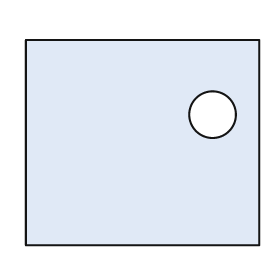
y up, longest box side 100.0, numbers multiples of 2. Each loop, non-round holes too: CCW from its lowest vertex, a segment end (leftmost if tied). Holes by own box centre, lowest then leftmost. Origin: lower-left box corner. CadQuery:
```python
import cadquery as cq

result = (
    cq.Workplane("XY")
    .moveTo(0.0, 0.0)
    .lineTo(100.0, 0.0)
    .lineTo(100.0, 88.0)
    .lineTo(0.0, 88.0)
    .close()
    .moveTo(80.0, 56.0)
    .circle(10.0)
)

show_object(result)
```